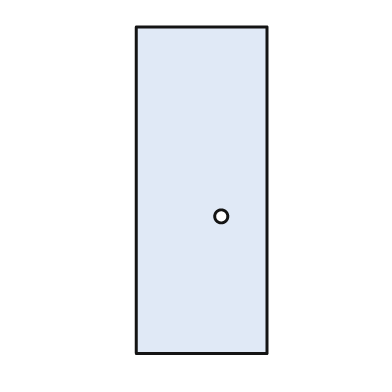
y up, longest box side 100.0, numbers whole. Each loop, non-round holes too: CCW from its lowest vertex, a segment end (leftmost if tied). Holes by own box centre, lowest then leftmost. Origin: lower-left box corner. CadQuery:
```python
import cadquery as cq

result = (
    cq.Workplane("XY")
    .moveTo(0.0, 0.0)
    .lineTo(40.0, 0.0)
    .lineTo(40.0, 100.0)
    .lineTo(0.0, 100.0)
    .close()
    .moveTo(26.0, 42.0)
    .circle(2.0)
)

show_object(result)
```